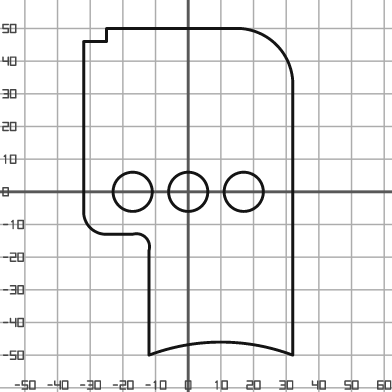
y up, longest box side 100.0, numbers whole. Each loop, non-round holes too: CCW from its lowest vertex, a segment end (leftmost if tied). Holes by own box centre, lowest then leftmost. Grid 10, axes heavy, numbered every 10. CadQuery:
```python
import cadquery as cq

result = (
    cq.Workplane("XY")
    .moveTo(-12.0, -50.0)
    .threePointArc((10.0, -46.0), (32.0, -50.0))
    .lineTo(32.0, 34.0)
    .threePointArc((27.0, 45.0), (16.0, 50.0))
    .lineTo(-25.0, 50.0)
    .lineTo(-25.0, 46.0)
    .lineTo(-32.0, 46.0)
    .lineTo(-32.0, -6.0)
    .threePointArc((-30.0, -11.0), (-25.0, -13.0))
    .lineTo(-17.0, -13.0)
    .threePointArc((-13.0, -14.0), (-12.0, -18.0))
    .close()
    .moveTo(-17.0, 0.0)
    .circle(6.0)
    .moveTo(0.0, 0.0)
    .circle(6.0)
    .moveTo(17.0, 0.0)
    .circle(6.0)
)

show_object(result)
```